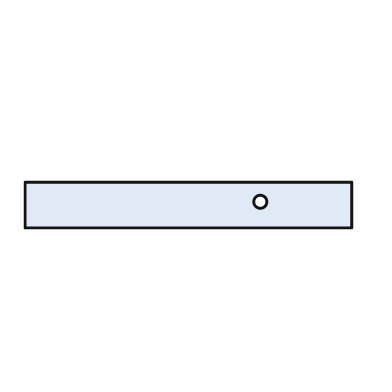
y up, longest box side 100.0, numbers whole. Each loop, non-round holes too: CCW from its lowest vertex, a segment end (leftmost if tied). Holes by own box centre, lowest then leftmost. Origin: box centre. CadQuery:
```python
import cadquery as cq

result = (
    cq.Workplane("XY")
    .moveTo(-50.0, -7.0)
    .lineTo(50.0, -7.0)
    .lineTo(50.0, 7.0)
    .lineTo(-50.0, 7.0)
    .close()
    .moveTo(22.0, 1.0)
    .circle(2.0)
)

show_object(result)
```